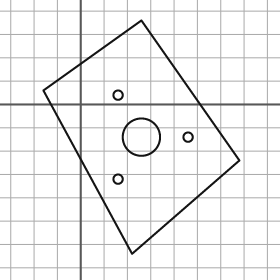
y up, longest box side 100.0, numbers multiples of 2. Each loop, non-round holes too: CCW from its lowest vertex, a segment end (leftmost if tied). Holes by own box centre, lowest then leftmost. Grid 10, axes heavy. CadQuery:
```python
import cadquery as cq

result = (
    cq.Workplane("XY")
    .moveTo(22.0, -64.0)
    .lineTo(68.0, -24.0)
    .lineTo(26.0, 36.0)
    .lineTo(-16.0, 6.0)
    .close()
    .moveTo(16.0, -32.0)
    .circle(2.0)
    .moveTo(26.0, -14.0)
    .circle(8.0)
    .moveTo(46.0, -14.0)
    .circle(2.0)
    .moveTo(16.0, 4.0)
    .circle(2.0)
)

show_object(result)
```